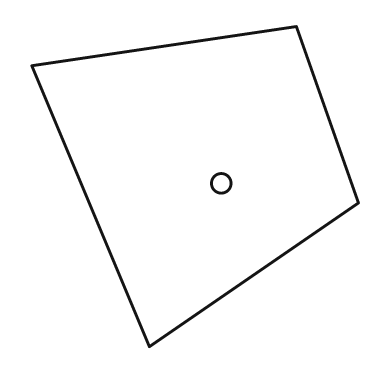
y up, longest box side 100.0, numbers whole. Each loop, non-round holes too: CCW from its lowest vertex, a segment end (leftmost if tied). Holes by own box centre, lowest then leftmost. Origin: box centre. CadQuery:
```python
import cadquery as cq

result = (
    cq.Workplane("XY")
    .moveTo(-14.0, -49.0)
    .lineTo(50.0, -5.0)
    .lineTo(31.0, 49.0)
    .lineTo(-50.0, 37.0)
    .close()
    .moveTo(8.0, 1.0)
    .circle(3.0)
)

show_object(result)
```